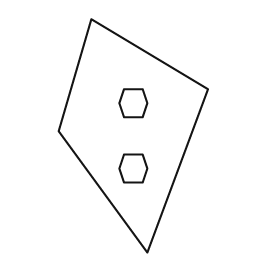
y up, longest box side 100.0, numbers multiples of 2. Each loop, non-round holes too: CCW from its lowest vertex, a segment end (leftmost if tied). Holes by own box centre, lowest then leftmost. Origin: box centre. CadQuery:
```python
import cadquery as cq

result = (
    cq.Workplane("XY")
    .moveTo(6.0, -50.0)
    .lineTo(32.0, 20.0)
    .lineTo(-18.0, 50.0)
    .lineTo(-32.0, 2.0)
    .close()
    .moveTo(-4.0, -20.0)
    .lineTo(4.0, -20.0)
    .lineTo(6.0, -14.0)
    .lineTo(4.0, -8.0)
    .lineTo(-4.0, -8.0)
    .lineTo(-6.0, -14.0)
    .close()
    .moveTo(-4.0, 8.0)
    .lineTo(4.0, 8.0)
    .lineTo(6.0, 14.0)
    .lineTo(4.0, 20.0)
    .lineTo(-4.0, 20.0)
    .lineTo(-6.0, 14.0)
    .close()
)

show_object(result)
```